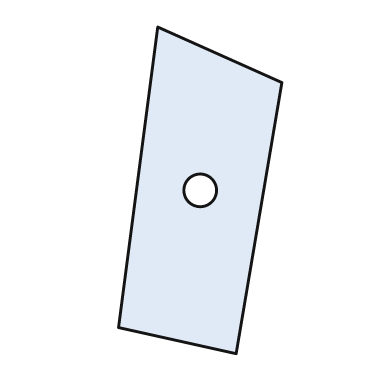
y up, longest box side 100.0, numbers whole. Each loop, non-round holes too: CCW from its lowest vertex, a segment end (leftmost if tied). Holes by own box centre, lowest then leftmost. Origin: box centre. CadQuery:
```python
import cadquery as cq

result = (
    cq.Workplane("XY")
    .moveTo(11.0, -50.0)
    .lineTo(25.0, 33.0)
    .lineTo(-13.0, 50.0)
    .lineTo(-25.0, -42.0)
    .close()
    .moveTo(0.0, 0.0)
    .circle(5.0)
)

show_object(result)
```